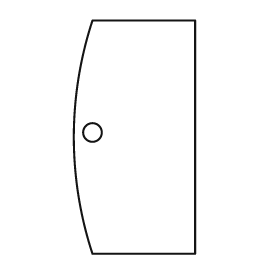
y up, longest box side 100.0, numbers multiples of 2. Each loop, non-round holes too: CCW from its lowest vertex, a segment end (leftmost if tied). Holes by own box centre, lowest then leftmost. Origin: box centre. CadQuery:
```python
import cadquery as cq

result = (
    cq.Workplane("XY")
    .moveTo(-18.0, -50.0)
    .lineTo(26.0, -50.0)
    .lineTo(26.0, 50.0)
    .lineTo(-18.0, 50.0)
    .threePointArc((-26.0, 0.0), (-18.0, -50.0))
    .close()
    .moveTo(-18.0, 2.0)
    .circle(4.0)
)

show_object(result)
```